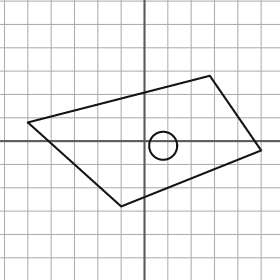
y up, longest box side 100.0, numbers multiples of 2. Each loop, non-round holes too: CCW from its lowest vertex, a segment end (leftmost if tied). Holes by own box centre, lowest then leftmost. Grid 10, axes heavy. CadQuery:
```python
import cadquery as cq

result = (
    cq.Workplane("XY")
    .moveTo(-10.0, -28.0)
    .lineTo(50.0, -4.0)
    .lineTo(28.0, 28.0)
    .lineTo(-50.0, 8.0)
    .close()
    .moveTo(8.0, -2.0)
    .circle(6.0)
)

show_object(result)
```